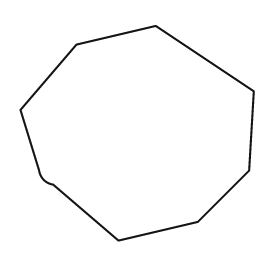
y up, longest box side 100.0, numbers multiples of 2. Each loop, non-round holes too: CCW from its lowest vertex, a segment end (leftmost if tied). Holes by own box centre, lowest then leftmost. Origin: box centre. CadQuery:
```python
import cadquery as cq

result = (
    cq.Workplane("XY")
    .moveTo(-8.0, -46.0)
    .lineTo(26.0, -38.0)
    .lineTo(48.0, -16.0)
    .lineTo(50.0, 18.0)
    .lineTo(8.0, 46.0)
    .lineTo(-26.0, 38.0)
    .lineTo(-50.0, 10.0)
    .lineTo(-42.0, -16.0)
    .threePointArc((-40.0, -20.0), (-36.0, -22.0))
    .close()
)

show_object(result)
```